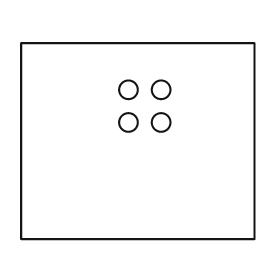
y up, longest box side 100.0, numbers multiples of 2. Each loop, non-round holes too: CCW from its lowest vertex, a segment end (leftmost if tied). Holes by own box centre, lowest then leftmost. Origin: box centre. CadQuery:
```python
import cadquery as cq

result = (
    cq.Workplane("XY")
    .moveTo(-50.0, -42.0)
    .lineTo(50.0, -42.0)
    .lineTo(50.0, 42.0)
    .lineTo(-50.0, 42.0)
    .close()
    .moveTo(-4.0, 8.0)
    .circle(4.0)
    .moveTo(10.0, 8.0)
    .circle(4.0)
    .moveTo(-4.0, 22.0)
    .circle(4.0)
    .moveTo(10.0, 22.0)
    .circle(4.0)
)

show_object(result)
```